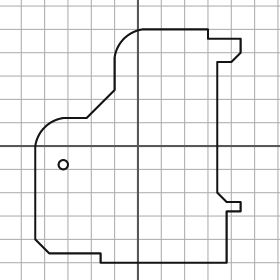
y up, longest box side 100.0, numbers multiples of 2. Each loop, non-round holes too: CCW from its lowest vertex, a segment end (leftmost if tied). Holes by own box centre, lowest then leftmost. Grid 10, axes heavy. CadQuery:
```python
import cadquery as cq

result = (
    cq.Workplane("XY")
    .moveTo(-16.0, -50.0)
    .lineTo(38.0, -50.0)
    .lineTo(38.0, -28.0)
    .lineTo(44.0, -28.0)
    .lineTo(44.0, -24.0)
    .lineTo(38.0, -24.0)
    .lineTo(34.0, -20.0)
    .lineTo(34.0, 36.0)
    .lineTo(40.0, 36.0)
    .lineTo(44.0, 40.0)
    .lineTo(44.0, 46.0)
    .lineTo(30.0, 46.0)
    .lineTo(30.0, 50.0)
    .lineTo(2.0, 50.0)
    .threePointArc((-6.0, 46.0), (-10.0, 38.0))
    .lineTo(-10.0, 24.0)
    .lineTo(-22.0, 12.0)
    .lineTo(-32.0, 12.0)
    .threePointArc((-40.0, 8.0), (-44.0, 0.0))
    .lineTo(-44.0, -40.0)
    .lineTo(-38.0, -46.0)
    .lineTo(-16.0, -46.0)
    .close()
    .moveTo(-32.0, -8.0)
    .circle(2.0)
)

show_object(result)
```